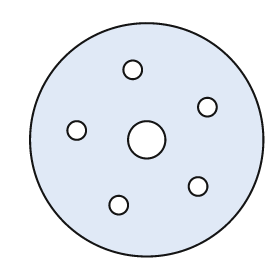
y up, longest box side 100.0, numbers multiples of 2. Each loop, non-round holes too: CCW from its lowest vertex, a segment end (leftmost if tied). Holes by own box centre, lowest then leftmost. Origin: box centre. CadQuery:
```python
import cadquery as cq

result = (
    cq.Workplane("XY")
    .moveTo(0.0, 0.0)
    .circle(50.0)
    .moveTo(-12.0, -28.0)
    .circle(4.0)
    .moveTo(22.0, -20.0)
    .circle(4.0)
    .moveTo(0.0, 0.0)
    .circle(8.0)
    .moveTo(-30.0, 4.0)
    .circle(4.0)
    .moveTo(26.0, 14.0)
    .circle(4.0)
    .moveTo(-6.0, 30.0)
    .circle(4.0)
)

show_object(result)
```